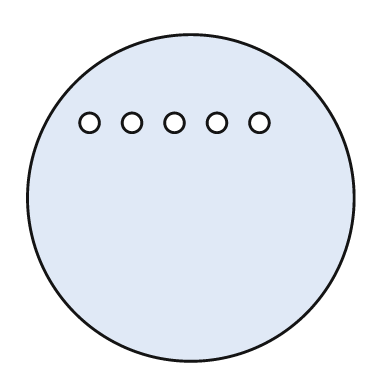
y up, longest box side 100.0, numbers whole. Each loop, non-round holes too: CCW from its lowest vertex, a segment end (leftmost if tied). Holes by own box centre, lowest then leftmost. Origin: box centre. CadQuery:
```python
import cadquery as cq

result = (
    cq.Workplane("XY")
    .moveTo(0.0, 0.0)
    .circle(50.0)
    .moveTo(-31.0, 23.0)
    .circle(3.0)
    .moveTo(-18.0, 23.0)
    .circle(3.0)
    .moveTo(-5.0, 23.0)
    .circle(3.0)
    .moveTo(8.0, 23.0)
    .circle(3.0)
    .moveTo(21.0, 23.0)
    .circle(3.0)
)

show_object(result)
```